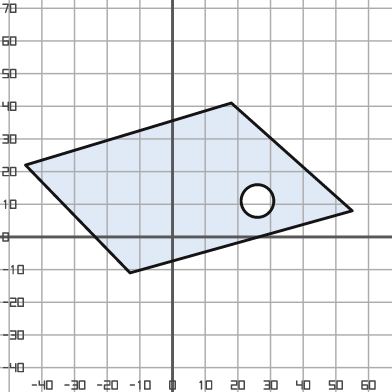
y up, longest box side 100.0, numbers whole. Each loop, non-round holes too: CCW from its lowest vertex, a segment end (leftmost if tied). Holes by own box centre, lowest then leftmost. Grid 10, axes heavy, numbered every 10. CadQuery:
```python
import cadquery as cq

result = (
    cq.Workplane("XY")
    .moveTo(-13.0, -11.0)
    .lineTo(55.0, 8.0)
    .lineTo(18.0, 41.0)
    .lineTo(-45.0, 22.0)
    .close()
    .moveTo(26.0, 11.0)
    .circle(5.0)
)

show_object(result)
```